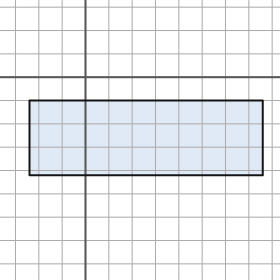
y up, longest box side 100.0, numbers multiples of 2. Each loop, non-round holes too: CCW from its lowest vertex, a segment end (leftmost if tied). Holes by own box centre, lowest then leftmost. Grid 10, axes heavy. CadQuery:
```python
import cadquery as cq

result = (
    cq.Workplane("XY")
    .moveTo(-24.0, -42.0)
    .lineTo(76.0, -42.0)
    .lineTo(76.0, -10.0)
    .lineTo(-24.0, -10.0)
    .close()
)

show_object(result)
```